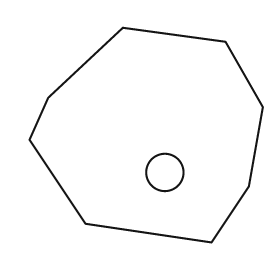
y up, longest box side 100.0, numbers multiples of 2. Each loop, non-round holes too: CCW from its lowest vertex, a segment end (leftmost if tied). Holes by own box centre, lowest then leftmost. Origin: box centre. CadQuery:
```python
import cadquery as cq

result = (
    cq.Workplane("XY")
    .moveTo(28.0, -46.0)
    .lineTo(44.0, -22.0)
    .lineTo(50.0, 12.0)
    .lineTo(34.0, 40.0)
    .lineTo(-10.0, 46.0)
    .lineTo(-42.0, 16.0)
    .lineTo(-50.0, -2.0)
    .lineTo(-26.0, -38.0)
    .close()
    .moveTo(8.0, -16.0)
    .circle(8.0)
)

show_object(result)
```